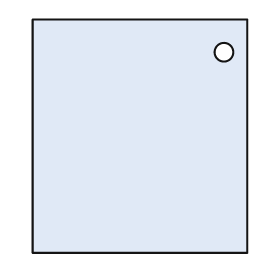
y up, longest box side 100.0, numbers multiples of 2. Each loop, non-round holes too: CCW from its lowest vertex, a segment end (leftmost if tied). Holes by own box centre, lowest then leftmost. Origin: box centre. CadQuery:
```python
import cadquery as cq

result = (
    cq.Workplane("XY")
    .moveTo(-46.0, -50.0)
    .lineTo(46.0, -50.0)
    .lineTo(46.0, 50.0)
    .lineTo(-46.0, 50.0)
    .close()
    .moveTo(36.0, 36.0)
    .circle(4.0)
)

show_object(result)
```